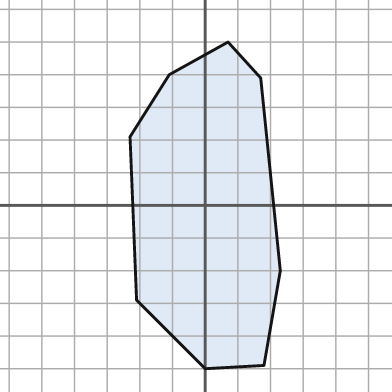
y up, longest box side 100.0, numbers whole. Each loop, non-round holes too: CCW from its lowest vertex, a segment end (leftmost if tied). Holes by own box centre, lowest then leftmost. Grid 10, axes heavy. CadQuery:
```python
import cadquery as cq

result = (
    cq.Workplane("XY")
    .moveTo(0.0, -50.0)
    .lineTo(18.0, -49.0)
    .lineTo(23.0, -20.0)
    .lineTo(17.0, 39.0)
    .lineTo(7.0, 50.0)
    .lineTo(-11.0, 40.0)
    .lineTo(-23.0, 21.0)
    .lineTo(-21.0, -29.0)
    .close()
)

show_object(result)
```